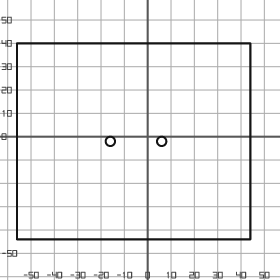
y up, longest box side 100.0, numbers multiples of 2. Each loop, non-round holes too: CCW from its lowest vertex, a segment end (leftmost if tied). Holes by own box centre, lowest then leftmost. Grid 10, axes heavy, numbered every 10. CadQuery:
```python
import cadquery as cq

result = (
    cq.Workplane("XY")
    .moveTo(-56.0, -44.0)
    .lineTo(44.0, -44.0)
    .lineTo(44.0, 40.0)
    .lineTo(-56.0, 40.0)
    .close()
    .moveTo(-16.0, -2.0)
    .circle(2.0)
    .moveTo(6.0, -2.0)
    .circle(2.0)
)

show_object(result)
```